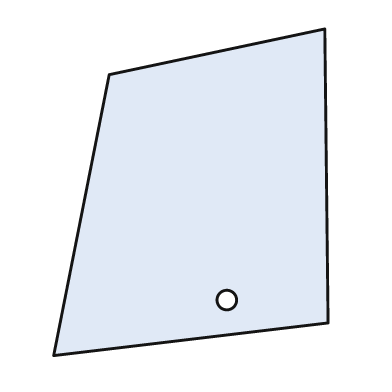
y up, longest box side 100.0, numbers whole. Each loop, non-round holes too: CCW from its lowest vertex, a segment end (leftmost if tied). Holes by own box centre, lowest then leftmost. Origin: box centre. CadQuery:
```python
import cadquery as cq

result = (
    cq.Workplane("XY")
    .moveTo(-42.0, -50.0)
    .lineTo(42.0, -40.0)
    .lineTo(41.0, 50.0)
    .lineTo(-25.0, 36.0)
    .close()
    .moveTo(11.0, -33.0)
    .circle(3.0)
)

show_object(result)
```